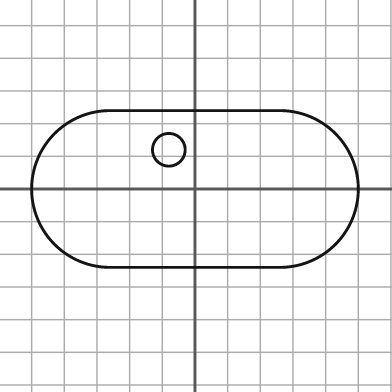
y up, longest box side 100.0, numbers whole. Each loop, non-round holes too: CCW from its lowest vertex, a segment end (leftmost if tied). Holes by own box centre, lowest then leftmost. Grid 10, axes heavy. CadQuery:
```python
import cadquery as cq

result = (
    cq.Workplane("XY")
    .moveTo(-26.0, -24.0)
    .lineTo(26.0, -24.0)
    .threePointArc((50.0, 0.0), (26.0, 24.0))
    .lineTo(-26.0, 24.0)
    .threePointArc((-50.0, 0.0), (-26.0, -24.0))
    .close()
    .moveTo(-8.0, 12.0)
    .circle(5.0)
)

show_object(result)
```